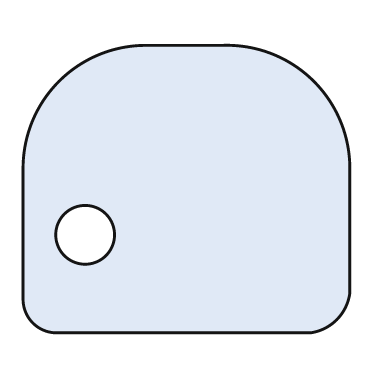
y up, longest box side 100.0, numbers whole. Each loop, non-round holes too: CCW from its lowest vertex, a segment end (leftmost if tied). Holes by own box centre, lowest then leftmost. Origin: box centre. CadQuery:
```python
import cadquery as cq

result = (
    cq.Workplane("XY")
    .moveTo(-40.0, -44.0)
    .lineTo(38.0, -44.0)
    .threePointArc((46.0, -40.0), (50.0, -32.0))
    .lineTo(50.0, 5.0)
    .threePointArc((39.0, 33.0), (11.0, 44.0))
    .lineTo(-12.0, 44.0)
    .threePointArc((-39.0, 33.0), (-50.0, 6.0))
    .lineTo(-50.0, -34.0)
    .threePointArc((-47.0, -41.0), (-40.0, -44.0))
    .close()
    .moveTo(-31.0, -14.0)
    .circle(9.0)
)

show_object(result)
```